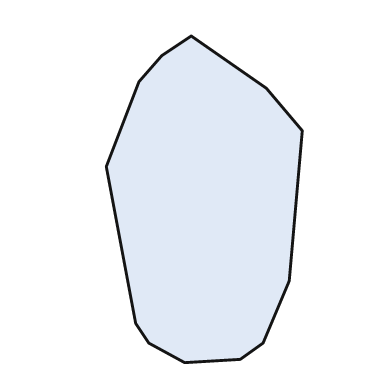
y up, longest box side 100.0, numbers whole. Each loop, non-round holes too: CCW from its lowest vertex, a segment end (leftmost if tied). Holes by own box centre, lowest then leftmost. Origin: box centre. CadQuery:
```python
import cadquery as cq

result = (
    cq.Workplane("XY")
    .moveTo(-6.0, -50.0)
    .lineTo(11.0, -49.0)
    .lineTo(18.0, -44.0)
    .lineTo(26.0, -25.0)
    .lineTo(30.0, 21.0)
    .lineTo(19.0, 34.0)
    .lineTo(-4.0, 50.0)
    .lineTo(-13.0, 44.0)
    .lineTo(-20.0, 36.0)
    .lineTo(-30.0, 10.0)
    .lineTo(-21.0, -38.0)
    .lineTo(-17.0, -44.0)
    .close()
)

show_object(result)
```